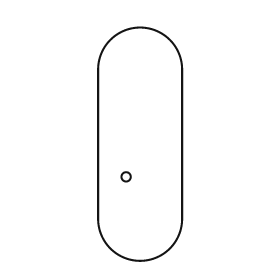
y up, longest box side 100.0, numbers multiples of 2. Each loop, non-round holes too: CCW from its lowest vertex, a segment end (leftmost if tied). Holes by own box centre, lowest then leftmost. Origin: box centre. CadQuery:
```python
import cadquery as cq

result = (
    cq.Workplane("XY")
    .moveTo(-18.0, -32.0)
    .threePointArc((0.0, -50.0), (18.0, -32.0))
    .lineTo(18.0, 32.0)
    .threePointArc((0.0, 50.0), (-18.0, 32.0))
    .close()
    .moveTo(-6.0, -14.0)
    .circle(2.0)
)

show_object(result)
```